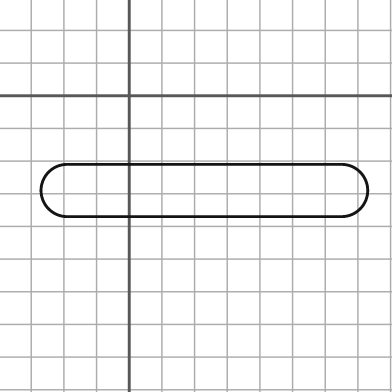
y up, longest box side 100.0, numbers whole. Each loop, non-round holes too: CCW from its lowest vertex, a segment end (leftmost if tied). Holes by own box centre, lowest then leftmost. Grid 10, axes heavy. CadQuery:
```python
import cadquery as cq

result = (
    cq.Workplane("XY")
    .moveTo(-19.0, -37.0)
    .lineTo(65.0, -37.0)
    .threePointArc((73.0, -29.0), (65.0, -21.0))
    .lineTo(-19.0, -21.0)
    .threePointArc((-27.0, -29.0), (-19.0, -37.0))
    .close()
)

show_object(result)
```